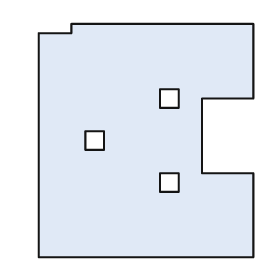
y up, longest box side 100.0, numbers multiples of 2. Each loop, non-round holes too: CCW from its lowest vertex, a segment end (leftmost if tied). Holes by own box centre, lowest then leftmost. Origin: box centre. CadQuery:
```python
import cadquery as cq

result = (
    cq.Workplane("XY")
    .moveTo(-46.0, -50.0)
    .lineTo(46.0, -50.0)
    .lineTo(46.0, -14.0)
    .lineTo(24.0, -14.0)
    .lineTo(24.0, 18.0)
    .lineTo(46.0, 18.0)
    .lineTo(46.0, 50.0)
    .lineTo(-32.0, 50.0)
    .lineTo(-32.0, 46.0)
    .lineTo(-46.0, 46.0)
    .close()
    .moveTo(6.0, -22.0)
    .lineTo(14.0, -22.0)
    .lineTo(14.0, -14.0)
    .lineTo(6.0, -14.0)
    .close()
    .moveTo(-26.0, -4.0)
    .lineTo(-18.0, -4.0)
    .lineTo(-18.0, 4.0)
    .lineTo(-26.0, 4.0)
    .close()
    .moveTo(6.0, 14.0)
    .lineTo(14.0, 14.0)
    .lineTo(14.0, 22.0)
    .lineTo(6.0, 22.0)
    .close()
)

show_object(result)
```